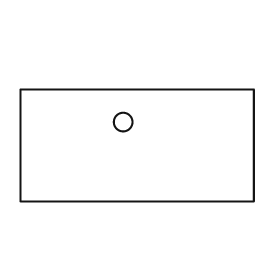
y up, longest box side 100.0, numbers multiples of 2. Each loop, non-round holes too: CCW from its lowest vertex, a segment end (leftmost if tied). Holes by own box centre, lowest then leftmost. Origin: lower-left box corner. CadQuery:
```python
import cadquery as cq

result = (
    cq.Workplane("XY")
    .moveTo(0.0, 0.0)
    .lineTo(100.0, 0.0)
    .lineTo(100.0, 48.0)
    .lineTo(0.0, 48.0)
    .close()
    .moveTo(44.0, 34.0)
    .circle(4.0)
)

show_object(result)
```